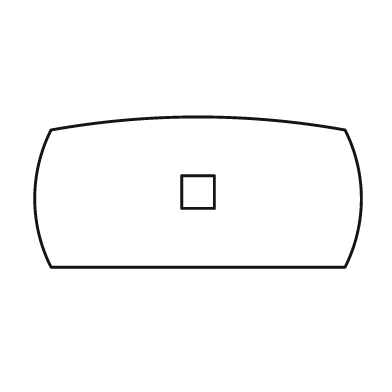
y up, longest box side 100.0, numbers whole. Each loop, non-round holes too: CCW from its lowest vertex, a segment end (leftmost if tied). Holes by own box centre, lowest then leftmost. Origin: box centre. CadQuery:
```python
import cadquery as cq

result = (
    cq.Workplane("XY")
    .moveTo(-45.0, -23.0)
    .lineTo(45.0, -23.0)
    .threePointArc((50.0, -2.0), (45.0, 19.0))
    .threePointArc((0.0, 23.0), (-45.0, 19.0))
    .threePointArc((-50.0, -2.0), (-45.0, -23.0))
    .close()
    .moveTo(-5.0, -5.0)
    .lineTo(5.0, -5.0)
    .lineTo(5.0, 5.0)
    .lineTo(-5.0, 5.0)
    .close()
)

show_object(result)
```